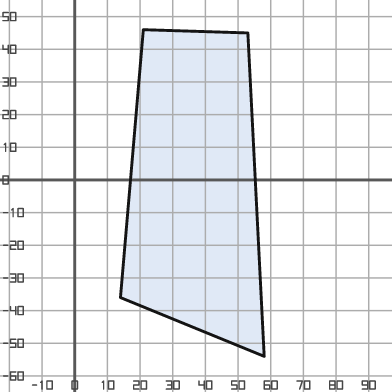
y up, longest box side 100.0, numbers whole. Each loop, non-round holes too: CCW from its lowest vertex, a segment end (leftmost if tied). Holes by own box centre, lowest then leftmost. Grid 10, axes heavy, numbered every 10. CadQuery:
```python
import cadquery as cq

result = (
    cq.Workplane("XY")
    .moveTo(58.0, -54.0)
    .lineTo(53.0, 45.0)
    .lineTo(21.0, 46.0)
    .lineTo(14.0, -36.0)
    .close()
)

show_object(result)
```